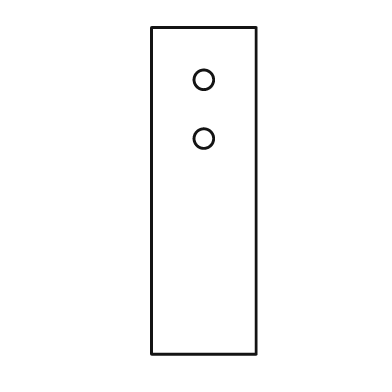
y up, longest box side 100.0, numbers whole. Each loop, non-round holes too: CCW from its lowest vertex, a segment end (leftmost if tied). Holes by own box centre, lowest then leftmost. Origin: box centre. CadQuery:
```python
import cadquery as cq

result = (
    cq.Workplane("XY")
    .moveTo(-16.0, -50.0)
    .lineTo(16.0, -50.0)
    .lineTo(16.0, 50.0)
    .lineTo(-16.0, 50.0)
    .close()
    .moveTo(0.0, 16.0)
    .circle(3.0)
    .moveTo(0.0, 34.0)
    .circle(3.0)
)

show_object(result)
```